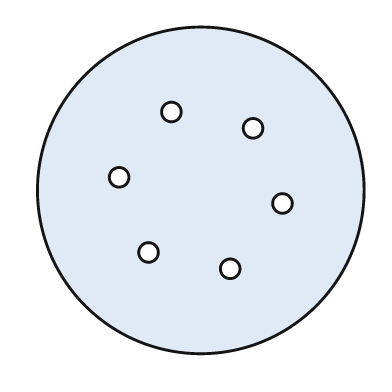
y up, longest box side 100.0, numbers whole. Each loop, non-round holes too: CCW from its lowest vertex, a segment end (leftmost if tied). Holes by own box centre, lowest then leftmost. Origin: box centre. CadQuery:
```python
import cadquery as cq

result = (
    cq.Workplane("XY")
    .moveTo(0.0, 0.0)
    .circle(50.0)
    .moveTo(9.0, -24.0)
    .circle(3.0)
    .moveTo(-16.0, -19.0)
    .circle(3.0)
    .moveTo(25.0, -4.0)
    .circle(3.0)
    .moveTo(-25.0, 4.0)
    .circle(3.0)
    .moveTo(16.0, 19.0)
    .circle(3.0)
    .moveTo(-9.0, 24.0)
    .circle(3.0)
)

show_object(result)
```